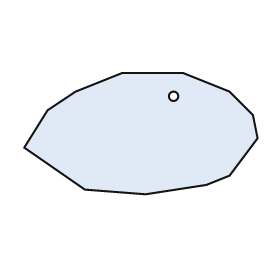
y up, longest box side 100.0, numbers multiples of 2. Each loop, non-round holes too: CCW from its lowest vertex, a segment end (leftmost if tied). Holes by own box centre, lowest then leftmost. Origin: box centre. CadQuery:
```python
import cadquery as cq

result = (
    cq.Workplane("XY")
    .moveTo(2.0, -26.0)
    .lineTo(28.0, -22.0)
    .lineTo(38.0, -18.0)
    .lineTo(50.0, -2.0)
    .lineTo(48.0, 8.0)
    .lineTo(38.0, 18.0)
    .lineTo(18.0, 26.0)
    .lineTo(-8.0, 26.0)
    .lineTo(-28.0, 18.0)
    .lineTo(-40.0, 10.0)
    .lineTo(-50.0, -6.0)
    .lineTo(-24.0, -24.0)
    .close()
    .moveTo(14.0, 16.0)
    .circle(2.0)
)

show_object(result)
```